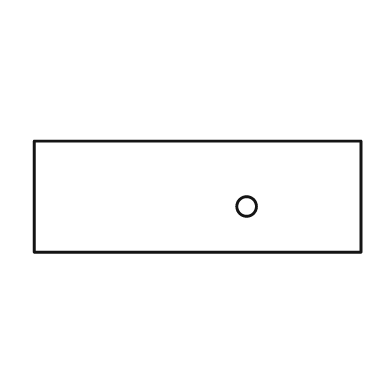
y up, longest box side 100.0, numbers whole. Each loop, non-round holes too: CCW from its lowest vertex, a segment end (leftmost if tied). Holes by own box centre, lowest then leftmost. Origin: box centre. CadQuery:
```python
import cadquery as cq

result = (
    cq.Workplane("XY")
    .moveTo(-50.0, -17.0)
    .lineTo(50.0, -17.0)
    .lineTo(50.0, 17.0)
    .lineTo(-50.0, 17.0)
    .close()
    .moveTo(15.0, -3.0)
    .circle(3.0)
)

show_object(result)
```